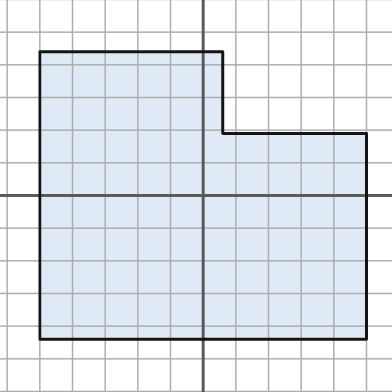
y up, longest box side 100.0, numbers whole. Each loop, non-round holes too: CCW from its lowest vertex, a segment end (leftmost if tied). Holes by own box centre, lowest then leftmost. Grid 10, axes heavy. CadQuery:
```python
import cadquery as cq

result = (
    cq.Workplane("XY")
    .moveTo(-50.0, -44.0)
    .lineTo(50.0, -44.0)
    .lineTo(50.0, 19.0)
    .lineTo(6.0, 19.0)
    .lineTo(6.0, 44.0)
    .lineTo(-50.0, 44.0)
    .close()
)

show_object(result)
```